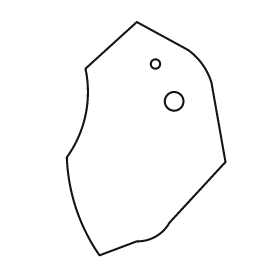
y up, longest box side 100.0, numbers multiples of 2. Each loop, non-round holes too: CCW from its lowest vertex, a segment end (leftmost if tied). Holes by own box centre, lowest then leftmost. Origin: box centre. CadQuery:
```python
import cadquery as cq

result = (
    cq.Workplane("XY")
    .moveTo(-20.0, -50.0)
    .lineTo(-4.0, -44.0)
    .threePointArc((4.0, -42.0), (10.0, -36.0))
    .lineTo(34.0, -10.0)
    .lineTo(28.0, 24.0)
    .threePointArc((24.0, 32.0), (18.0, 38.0))
    .lineTo(-4.0, 50.0)
    .lineTo(-26.0, 30.0)
    .threePointArc((-26.0, 10.0), (-34.0, -8.0))
    .threePointArc((-30.0, -30.0), (-20.0, -50.0))
    .close()
    .moveTo(12.0, 16.0)
    .circle(4.0)
    .moveTo(4.0, 32.0)
    .circle(2.0)
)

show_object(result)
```